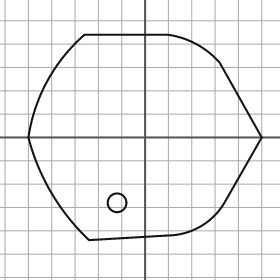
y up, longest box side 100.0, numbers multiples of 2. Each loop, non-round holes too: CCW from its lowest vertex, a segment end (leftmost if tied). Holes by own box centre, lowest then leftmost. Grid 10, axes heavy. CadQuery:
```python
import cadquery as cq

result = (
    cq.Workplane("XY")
    .moveTo(-24.0, -44.0)
    .lineTo(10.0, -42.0)
    .threePointArc((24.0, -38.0), (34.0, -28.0))
    .lineTo(50.0, 0.0)
    .lineTo(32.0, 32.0)
    .threePointArc((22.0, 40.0), (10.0, 44.0))
    .lineTo(-26.0, 44.0)
    .threePointArc((-42.0, 24.0), (-50.0, 0.0))
    .threePointArc((-40.0, -24.0), (-24.0, -44.0))
    .close()
    .moveTo(-12.0, -28.0)
    .circle(4.0)
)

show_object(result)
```